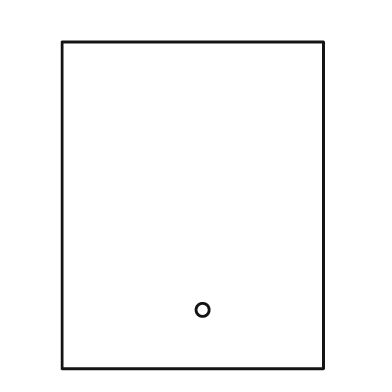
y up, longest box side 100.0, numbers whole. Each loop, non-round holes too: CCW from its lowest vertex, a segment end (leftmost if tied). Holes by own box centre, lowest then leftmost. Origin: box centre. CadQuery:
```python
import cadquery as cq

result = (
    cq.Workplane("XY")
    .moveTo(-40.0, -50.0)
    .lineTo(40.0, -50.0)
    .lineTo(40.0, 50.0)
    .lineTo(-40.0, 50.0)
    .close()
    .moveTo(3.0, -32.0)
    .circle(2.0)
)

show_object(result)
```